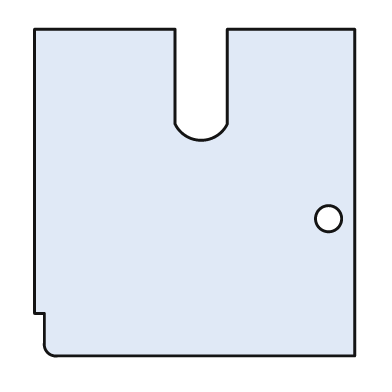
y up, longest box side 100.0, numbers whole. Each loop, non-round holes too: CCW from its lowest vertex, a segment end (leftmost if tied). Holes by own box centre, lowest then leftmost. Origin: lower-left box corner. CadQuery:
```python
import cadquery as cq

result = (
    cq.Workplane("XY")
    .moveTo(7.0, 0.0)
    .lineTo(98.0, 0.0)
    .lineTo(98.0, 100.0)
    .lineTo(59.0, 100.0)
    .lineTo(59.0, 71.0)
    .threePointArc((51.0, 66.0), (43.0, 71.0))
    .lineTo(43.0, 100.0)
    .lineTo(0.0, 100.0)
    .lineTo(0.0, 13.0)
    .lineTo(3.0, 13.0)
    .lineTo(3.0, 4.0)
    .threePointArc((4.0, 1.0), (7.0, 0.0))
    .close()
    .moveTo(90.0, 42.0)
    .circle(4.0)
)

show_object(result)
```